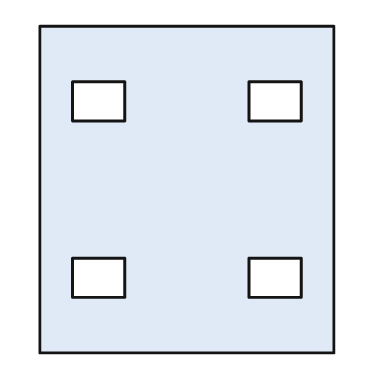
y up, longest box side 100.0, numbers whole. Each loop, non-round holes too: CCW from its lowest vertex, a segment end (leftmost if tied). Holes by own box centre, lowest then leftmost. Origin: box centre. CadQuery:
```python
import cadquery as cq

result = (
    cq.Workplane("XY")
    .moveTo(-45.0, -50.0)
    .lineTo(45.0, -50.0)
    .lineTo(45.0, 50.0)
    .lineTo(-45.0, 50.0)
    .close()
    .moveTo(-35.0, -33.0)
    .lineTo(-19.0, -33.0)
    .lineTo(-19.0, -21.0)
    .lineTo(-35.0, -21.0)
    .close()
    .moveTo(19.0, -33.0)
    .lineTo(35.0, -33.0)
    .lineTo(35.0, -21.0)
    .lineTo(19.0, -21.0)
    .close()
    .moveTo(-35.0, 21.0)
    .lineTo(-19.0, 21.0)
    .lineTo(-19.0, 33.0)
    .lineTo(-35.0, 33.0)
    .close()
    .moveTo(19.0, 21.0)
    .lineTo(35.0, 21.0)
    .lineTo(35.0, 33.0)
    .lineTo(19.0, 33.0)
    .close()
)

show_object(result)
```